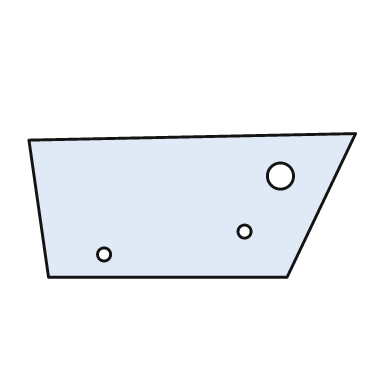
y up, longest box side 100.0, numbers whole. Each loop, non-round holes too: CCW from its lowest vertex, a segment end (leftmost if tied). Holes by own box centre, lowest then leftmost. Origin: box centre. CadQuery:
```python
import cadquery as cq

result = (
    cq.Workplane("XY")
    .moveTo(-44.0, -22.0)
    .lineTo(29.0, -22.0)
    .lineTo(50.0, 22.0)
    .lineTo(-50.0, 20.0)
    .close()
    .moveTo(-27.0, -15.0)
    .circle(2.0)
    .moveTo(16.0, -8.0)
    .circle(2.0)
    .moveTo(27.0, 9.0)
    .circle(4.0)
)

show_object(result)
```